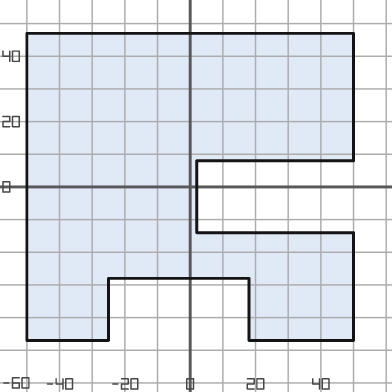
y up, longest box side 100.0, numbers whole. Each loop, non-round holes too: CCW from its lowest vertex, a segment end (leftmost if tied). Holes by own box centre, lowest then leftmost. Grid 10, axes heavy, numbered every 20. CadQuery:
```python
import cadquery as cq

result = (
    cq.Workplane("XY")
    .moveTo(-50.0, -47.0)
    .lineTo(-25.0, -47.0)
    .lineTo(-25.0, -28.0)
    .lineTo(18.0, -28.0)
    .lineTo(18.0, -47.0)
    .lineTo(50.0, -47.0)
    .lineTo(50.0, -14.0)
    .lineTo(2.0, -14.0)
    .lineTo(2.0, 8.0)
    .lineTo(50.0, 8.0)
    .lineTo(50.0, 47.0)
    .lineTo(-50.0, 47.0)
    .close()
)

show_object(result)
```